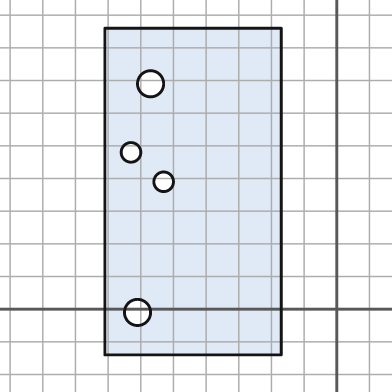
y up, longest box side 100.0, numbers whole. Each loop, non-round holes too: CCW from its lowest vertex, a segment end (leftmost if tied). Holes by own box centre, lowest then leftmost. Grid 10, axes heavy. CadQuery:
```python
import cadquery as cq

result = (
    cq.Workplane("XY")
    .moveTo(-71.0, -14.0)
    .lineTo(-17.0, -14.0)
    .lineTo(-17.0, 86.0)
    .lineTo(-71.0, 86.0)
    .close()
    .moveTo(-61.0, -1.0)
    .circle(4.0)
    .moveTo(-53.0, 39.0)
    .circle(3.0)
    .moveTo(-63.0, 48.0)
    .circle(3.0)
    .moveTo(-57.0, 69.0)
    .circle(4.0)
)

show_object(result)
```